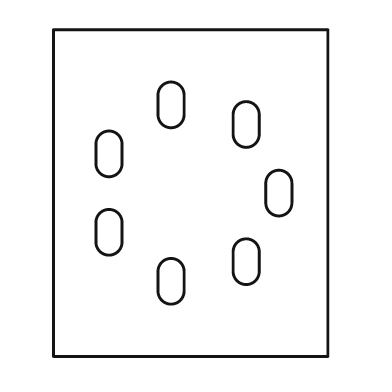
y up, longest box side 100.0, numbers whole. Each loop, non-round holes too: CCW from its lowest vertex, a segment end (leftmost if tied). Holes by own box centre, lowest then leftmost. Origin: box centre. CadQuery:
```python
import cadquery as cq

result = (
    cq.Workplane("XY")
    .moveTo(-42.0, -50.0)
    .lineTo(42.0, -50.0)
    .lineTo(42.0, 50.0)
    .lineTo(-42.0, 50.0)
    .close()
    .moveTo(-10.0, -30.0)
    .threePointArc((-6.0, -34.0), (-2.0, -30.0))
    .lineTo(-2.0, -24.0)
    .threePointArc((-6.0, -20.0), (-10.0, -24.0))
    .close()
    .moveTo(13.0, -24.0)
    .threePointArc((17.0, -28.0), (21.0, -24.0))
    .lineTo(21.0, -18.0)
    .threePointArc((17.0, -14.0), (13.0, -18.0))
    .close()
    .moveTo(-29.0, -15.0)
    .threePointArc((-25.0, -19.0), (-21.0, -15.0))
    .lineTo(-21.0, -9.0)
    .threePointArc((-25.0, -5.0), (-29.0, -9.0))
    .close()
    .moveTo(23.0, -3.0)
    .threePointArc((27.0, -7.0), (31.0, -3.0))
    .lineTo(31.0, 3.0)
    .threePointArc((27.0, 7.0), (23.0, 3.0))
    .close()
    .moveTo(-29.0, 9.0)
    .threePointArc((-25.0, 5.0), (-21.0, 9.0))
    .lineTo(-21.0, 15.0)
    .threePointArc((-25.0, 19.0), (-29.0, 15.0))
    .close()
    .moveTo(13.0, 18.0)
    .threePointArc((17.0, 14.0), (21.0, 18.0))
    .lineTo(21.0, 24.0)
    .threePointArc((17.0, 28.0), (13.0, 24.0))
    .close()
    .moveTo(-10.0, 24.0)
    .threePointArc((-6.0, 20.0), (-2.0, 24.0))
    .lineTo(-2.0, 30.0)
    .threePointArc((-6.0, 34.0), (-10.0, 30.0))
    .close()
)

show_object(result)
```